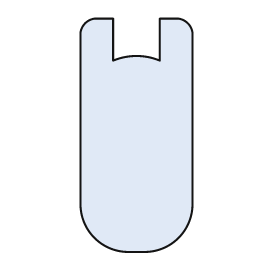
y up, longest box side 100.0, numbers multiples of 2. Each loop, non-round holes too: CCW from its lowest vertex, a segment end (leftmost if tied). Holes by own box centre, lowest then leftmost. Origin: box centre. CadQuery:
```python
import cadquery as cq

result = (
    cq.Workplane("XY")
    .moveTo(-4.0, -50.0)
    .lineTo(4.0, -50.0)
    .threePointArc((18.0, -44.0), (24.0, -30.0))
    .lineTo(24.0, 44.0)
    .threePointArc((22.0, 48.0), (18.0, 50.0))
    .lineTo(10.0, 50.0)
    .lineTo(10.0, 32.0)
    .threePointArc((0.0, 34.0), (-10.0, 32.0))
    .lineTo(-10.0, 50.0)
    .lineTo(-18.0, 50.0)
    .threePointArc((-22.0, 48.0), (-24.0, 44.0))
    .lineTo(-24.0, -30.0)
    .threePointArc((-18.0, -44.0), (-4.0, -50.0))
    .close()
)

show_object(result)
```